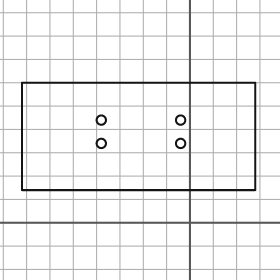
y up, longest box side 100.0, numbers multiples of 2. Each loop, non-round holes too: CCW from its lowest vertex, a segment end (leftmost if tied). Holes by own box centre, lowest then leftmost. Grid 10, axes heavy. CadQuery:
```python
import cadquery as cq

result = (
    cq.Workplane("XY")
    .moveTo(-72.0, 14.0)
    .lineTo(28.0, 14.0)
    .lineTo(28.0, 60.0)
    .lineTo(-72.0, 60.0)
    .close()
    .moveTo(-38.0, 34.0)
    .circle(2.0)
    .moveTo(-4.0, 34.0)
    .circle(2.0)
    .moveTo(-38.0, 44.0)
    .circle(2.0)
    .moveTo(-4.0, 44.0)
    .circle(2.0)
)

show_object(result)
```